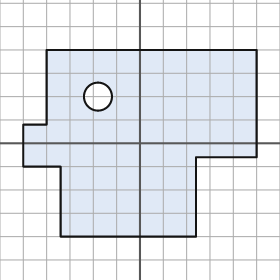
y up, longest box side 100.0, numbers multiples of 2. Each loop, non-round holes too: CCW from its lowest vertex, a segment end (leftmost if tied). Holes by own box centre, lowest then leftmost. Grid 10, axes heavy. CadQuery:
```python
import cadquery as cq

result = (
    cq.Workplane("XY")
    .moveTo(-34.0, -40.0)
    .lineTo(24.0, -40.0)
    .lineTo(24.0, -6.0)
    .lineTo(50.0, -6.0)
    .lineTo(50.0, 40.0)
    .lineTo(-40.0, 40.0)
    .lineTo(-40.0, 8.0)
    .lineTo(-50.0, 8.0)
    .lineTo(-50.0, -10.0)
    .lineTo(-34.0, -10.0)
    .close()
    .moveTo(-18.0, 20.0)
    .circle(6.0)
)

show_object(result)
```